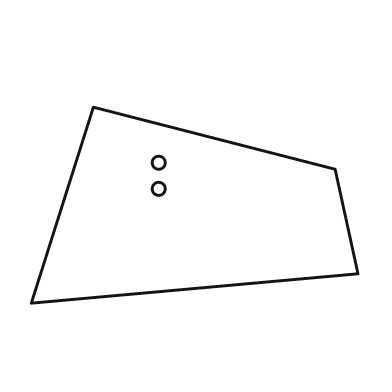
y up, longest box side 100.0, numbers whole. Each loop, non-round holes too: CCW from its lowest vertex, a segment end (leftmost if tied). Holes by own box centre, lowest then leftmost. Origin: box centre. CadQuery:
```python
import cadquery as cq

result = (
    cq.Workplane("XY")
    .moveTo(-50.0, -30.0)
    .lineTo(50.0, -21.0)
    .lineTo(43.0, 11.0)
    .lineTo(-31.0, 30.0)
    .close()
    .moveTo(-11.0, 5.0)
    .circle(2.0)
    .moveTo(-11.0, 13.0)
    .circle(2.0)
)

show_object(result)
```